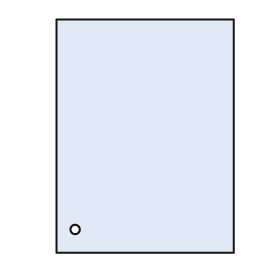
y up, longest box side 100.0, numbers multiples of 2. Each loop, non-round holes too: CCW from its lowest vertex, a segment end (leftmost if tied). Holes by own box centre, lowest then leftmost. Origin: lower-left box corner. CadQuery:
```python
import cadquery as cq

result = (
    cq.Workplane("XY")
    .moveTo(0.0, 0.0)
    .lineTo(76.0, 0.0)
    .lineTo(76.0, 100.0)
    .lineTo(0.0, 100.0)
    .close()
    .moveTo(8.0, 10.0)
    .circle(2.0)
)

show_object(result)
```